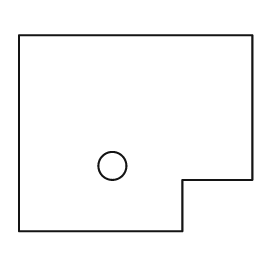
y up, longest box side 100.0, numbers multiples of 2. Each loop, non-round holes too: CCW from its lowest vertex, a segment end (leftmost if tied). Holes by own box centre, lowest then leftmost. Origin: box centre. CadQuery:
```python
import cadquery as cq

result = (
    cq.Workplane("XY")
    .moveTo(-50.0, -42.0)
    .lineTo(20.0, -42.0)
    .lineTo(20.0, -20.0)
    .lineTo(50.0, -20.0)
    .lineTo(50.0, 42.0)
    .lineTo(-50.0, 42.0)
    .close()
    .moveTo(-10.0, -14.0)
    .circle(6.0)
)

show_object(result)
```